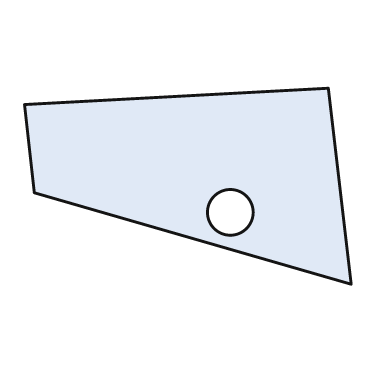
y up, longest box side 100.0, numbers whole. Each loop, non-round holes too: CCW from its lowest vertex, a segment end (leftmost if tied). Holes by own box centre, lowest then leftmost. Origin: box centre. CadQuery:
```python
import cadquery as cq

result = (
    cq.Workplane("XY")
    .moveTo(50.0, -30.0)
    .lineTo(43.0, 30.0)
    .lineTo(-50.0, 25.0)
    .lineTo(-47.0, -2.0)
    .close()
    .moveTo(13.0, -8.0)
    .circle(7.0)
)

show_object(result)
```